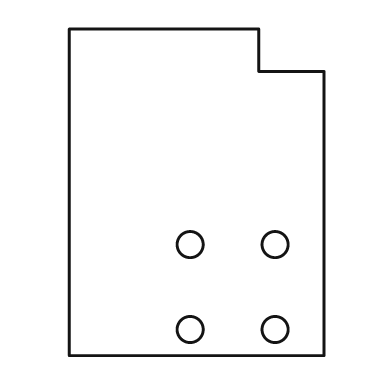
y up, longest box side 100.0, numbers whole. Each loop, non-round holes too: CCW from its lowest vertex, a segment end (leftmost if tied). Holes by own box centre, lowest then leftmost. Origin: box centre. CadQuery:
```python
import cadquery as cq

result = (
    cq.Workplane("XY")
    .moveTo(-39.0, -50.0)
    .lineTo(39.0, -50.0)
    .lineTo(39.0, 37.0)
    .lineTo(19.0, 37.0)
    .lineTo(19.0, 50.0)
    .lineTo(-39.0, 50.0)
    .close()
    .moveTo(-2.0, -42.0)
    .circle(4.0)
    .moveTo(24.0, -42.0)
    .circle(4.0)
    .moveTo(-2.0, -16.0)
    .circle(4.0)
    .moveTo(24.0, -16.0)
    .circle(4.0)
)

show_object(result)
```